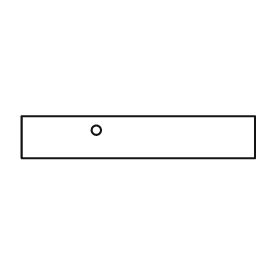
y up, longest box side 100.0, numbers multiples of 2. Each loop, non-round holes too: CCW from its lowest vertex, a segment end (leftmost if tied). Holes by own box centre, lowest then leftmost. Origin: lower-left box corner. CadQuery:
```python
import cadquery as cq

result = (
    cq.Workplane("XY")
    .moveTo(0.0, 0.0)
    .lineTo(100.0, 0.0)
    .lineTo(100.0, 18.0)
    .lineTo(0.0, 18.0)
    .close()
    .moveTo(32.0, 12.0)
    .circle(2.0)
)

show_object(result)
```